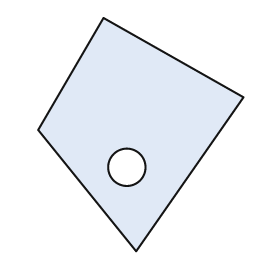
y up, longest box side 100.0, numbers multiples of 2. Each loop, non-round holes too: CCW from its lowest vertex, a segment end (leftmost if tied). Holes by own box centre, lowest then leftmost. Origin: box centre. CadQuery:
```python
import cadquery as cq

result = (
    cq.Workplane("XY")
    .moveTo(-2.0, -50.0)
    .lineTo(44.0, 16.0)
    .lineTo(-16.0, 50.0)
    .lineTo(-44.0, 2.0)
    .close()
    .moveTo(-6.0, -14.0)
    .circle(8.0)
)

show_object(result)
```